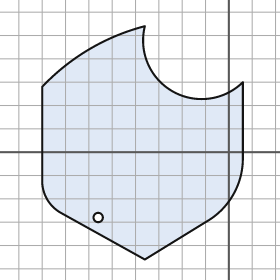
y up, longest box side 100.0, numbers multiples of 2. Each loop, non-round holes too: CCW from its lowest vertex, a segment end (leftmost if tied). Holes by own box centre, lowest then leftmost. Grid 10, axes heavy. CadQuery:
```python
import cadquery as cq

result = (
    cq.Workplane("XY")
    .moveTo(-36.0, -46.0)
    .lineTo(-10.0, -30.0)
    .threePointArc((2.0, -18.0), (6.0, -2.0))
    .lineTo(6.0, 30.0)
    .threePointArc((-24.0, 26.0), (-36.0, 54.0))
    .threePointArc((-60.0, 44.0), (-80.0, 28.0))
    .lineTo(-80.0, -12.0)
    .threePointArc((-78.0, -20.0), (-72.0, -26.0))
    .close()
    .moveTo(-56.0, -28.0)
    .circle(2.0)
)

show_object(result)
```